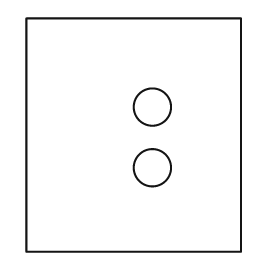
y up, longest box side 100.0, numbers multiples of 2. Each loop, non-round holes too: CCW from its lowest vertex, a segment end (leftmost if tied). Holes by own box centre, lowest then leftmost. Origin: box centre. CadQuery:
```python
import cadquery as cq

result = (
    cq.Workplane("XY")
    .moveTo(-46.0, -50.0)
    .lineTo(46.0, -50.0)
    .lineTo(46.0, 50.0)
    .lineTo(-46.0, 50.0)
    .close()
    .moveTo(8.0, -14.0)
    .circle(8.0)
    .moveTo(8.0, 12.0)
    .circle(8.0)
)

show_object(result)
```